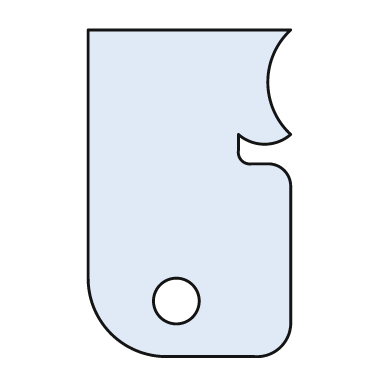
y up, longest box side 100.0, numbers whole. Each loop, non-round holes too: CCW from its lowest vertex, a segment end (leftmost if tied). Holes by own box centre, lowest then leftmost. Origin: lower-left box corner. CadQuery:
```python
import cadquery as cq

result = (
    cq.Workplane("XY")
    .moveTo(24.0, 0.0)
    .lineTo(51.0, 0.0)
    .threePointArc((59.0, 3.0), (62.0, 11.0))
    .lineTo(62.0, 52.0)
    .threePointArc((60.0, 57.0), (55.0, 59.0))
    .lineTo(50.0, 59.0)
    .threePointArc((47.0, 60.0), (46.0, 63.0))
    .lineTo(46.0, 68.0)
    .threePointArc((54.0, 65.0), (62.0, 68.0))
    .threePointArc((55.0, 84.0), (62.0, 100.0))
    .lineTo(0.0, 100.0)
    .lineTo(0.0, 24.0)
    .threePointArc((7.0, 7.0), (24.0, 0.0))
    .close()
    .moveTo(27.0, 17.0)
    .circle(7.0)
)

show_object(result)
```